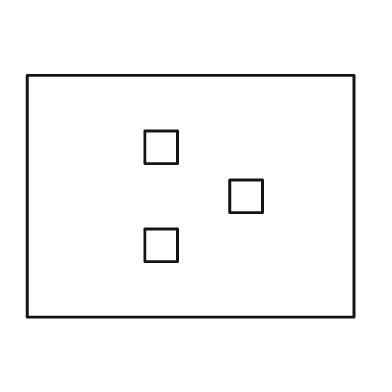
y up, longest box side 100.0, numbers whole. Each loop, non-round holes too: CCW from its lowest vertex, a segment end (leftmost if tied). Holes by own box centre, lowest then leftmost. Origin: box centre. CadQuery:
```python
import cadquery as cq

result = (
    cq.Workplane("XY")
    .moveTo(-50.0, -37.0)
    .lineTo(50.0, -37.0)
    .lineTo(50.0, 37.0)
    .lineTo(-50.0, 37.0)
    .close()
    .moveTo(-14.0, -20.0)
    .lineTo(-4.0, -20.0)
    .lineTo(-4.0, -10.0)
    .lineTo(-14.0, -10.0)
    .close()
    .moveTo(12.0, -5.0)
    .lineTo(22.0, -5.0)
    .lineTo(22.0, 5.0)
    .lineTo(12.0, 5.0)
    .close()
    .moveTo(-14.0, 10.0)
    .lineTo(-4.0, 10.0)
    .lineTo(-4.0, 20.0)
    .lineTo(-14.0, 20.0)
    .close()
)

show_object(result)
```